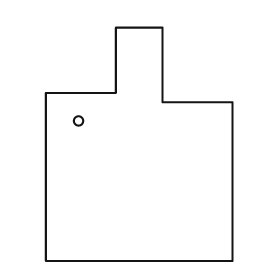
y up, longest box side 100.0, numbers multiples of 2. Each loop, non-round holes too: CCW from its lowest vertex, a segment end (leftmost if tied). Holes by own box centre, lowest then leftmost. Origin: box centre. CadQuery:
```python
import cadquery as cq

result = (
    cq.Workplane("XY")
    .moveTo(-40.0, -50.0)
    .lineTo(40.0, -50.0)
    .lineTo(40.0, 18.0)
    .lineTo(10.0, 18.0)
    .lineTo(10.0, 50.0)
    .lineTo(-10.0, 50.0)
    .lineTo(-10.0, 22.0)
    .lineTo(-40.0, 22.0)
    .close()
    .moveTo(-26.0, 10.0)
    .circle(2.0)
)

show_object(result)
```